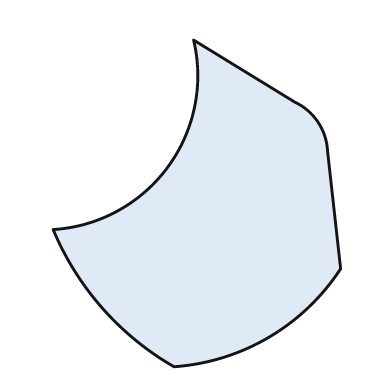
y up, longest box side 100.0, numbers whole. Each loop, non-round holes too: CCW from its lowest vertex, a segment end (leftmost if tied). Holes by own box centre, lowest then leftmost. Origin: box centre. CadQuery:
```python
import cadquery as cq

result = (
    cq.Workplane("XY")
    .moveTo(-7.0, -50.0)
    .threePointArc((22.0, -41.0), (44.0, -20.0))
    .lineTo(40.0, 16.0)
    .threePointArc((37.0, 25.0), (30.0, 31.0))
    .lineTo(-1.0, 50.0)
    .threePointArc((-9.0, 11.0), (-44.0, -8.0))
    .threePointArc((-29.0, -32.0), (-7.0, -50.0))
    .close()
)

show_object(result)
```